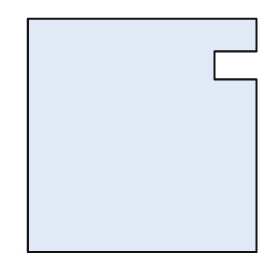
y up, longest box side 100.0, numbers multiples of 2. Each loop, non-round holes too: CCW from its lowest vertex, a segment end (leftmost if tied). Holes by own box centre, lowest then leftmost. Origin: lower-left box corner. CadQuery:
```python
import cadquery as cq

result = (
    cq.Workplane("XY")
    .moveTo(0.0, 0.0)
    .lineTo(98.0, 0.0)
    .lineTo(98.0, 74.0)
    .lineTo(80.0, 74.0)
    .lineTo(80.0, 86.0)
    .lineTo(98.0, 86.0)
    .lineTo(98.0, 100.0)
    .lineTo(0.0, 100.0)
    .close()
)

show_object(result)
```